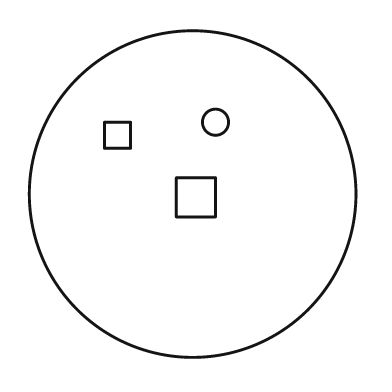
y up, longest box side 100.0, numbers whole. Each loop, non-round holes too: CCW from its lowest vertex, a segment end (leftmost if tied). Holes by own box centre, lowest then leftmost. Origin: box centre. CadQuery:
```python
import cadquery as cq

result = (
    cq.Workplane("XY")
    .moveTo(0.0, 0.0)
    .circle(50.0)
    .moveTo(-5.0, -7.0)
    .lineTo(7.0, -7.0)
    .lineTo(7.0, 5.0)
    .lineTo(-5.0, 5.0)
    .close()
    .moveTo(-27.0, 14.0)
    .lineTo(-19.0, 14.0)
    .lineTo(-19.0, 22.0)
    .lineTo(-27.0, 22.0)
    .close()
    .moveTo(7.0, 22.0)
    .circle(4.0)
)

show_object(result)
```